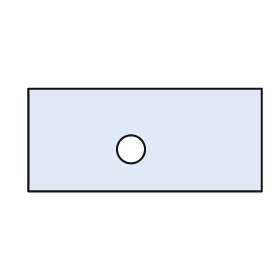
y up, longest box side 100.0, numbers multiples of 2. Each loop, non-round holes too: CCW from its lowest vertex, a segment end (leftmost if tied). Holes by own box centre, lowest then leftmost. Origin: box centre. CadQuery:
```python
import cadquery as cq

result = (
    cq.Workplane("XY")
    .moveTo(-50.0, -22.0)
    .lineTo(50.0, -22.0)
    .lineTo(50.0, 22.0)
    .lineTo(-50.0, 22.0)
    .close()
    .moveTo(-6.0, -4.0)
    .circle(6.0)
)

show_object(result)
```